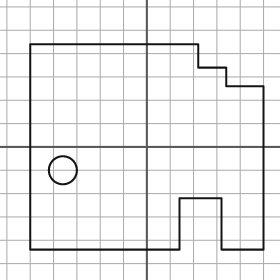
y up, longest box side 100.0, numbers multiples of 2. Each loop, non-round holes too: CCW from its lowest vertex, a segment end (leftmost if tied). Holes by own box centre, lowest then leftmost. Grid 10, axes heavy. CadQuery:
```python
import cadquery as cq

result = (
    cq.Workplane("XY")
    .moveTo(-50.0, -44.0)
    .lineTo(14.0, -44.0)
    .lineTo(14.0, -22.0)
    .lineTo(32.0, -22.0)
    .lineTo(32.0, -44.0)
    .lineTo(50.0, -44.0)
    .lineTo(50.0, 26.0)
    .lineTo(34.0, 26.0)
    .lineTo(34.0, 34.0)
    .lineTo(22.0, 34.0)
    .lineTo(22.0, 44.0)
    .lineTo(-50.0, 44.0)
    .close()
    .moveTo(-36.0, -10.0)
    .circle(6.0)
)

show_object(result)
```